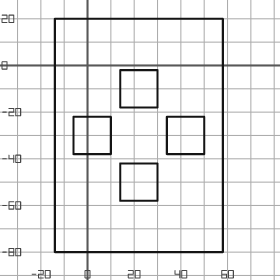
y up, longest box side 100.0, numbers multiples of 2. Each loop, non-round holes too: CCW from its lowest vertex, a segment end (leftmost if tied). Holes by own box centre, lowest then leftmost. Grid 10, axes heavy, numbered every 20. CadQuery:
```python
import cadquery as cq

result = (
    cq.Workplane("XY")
    .moveTo(-14.0, -80.0)
    .lineTo(58.0, -80.0)
    .lineTo(58.0, 20.0)
    .lineTo(-14.0, 20.0)
    .close()
    .moveTo(14.0, -58.0)
    .lineTo(30.0, -58.0)
    .lineTo(30.0, -42.0)
    .lineTo(14.0, -42.0)
    .close()
    .moveTo(-6.0, -38.0)
    .lineTo(10.0, -38.0)
    .lineTo(10.0, -22.0)
    .lineTo(-6.0, -22.0)
    .close()
    .moveTo(34.0, -38.0)
    .lineTo(50.0, -38.0)
    .lineTo(50.0, -22.0)
    .lineTo(34.0, -22.0)
    .close()
    .moveTo(14.0, -18.0)
    .lineTo(30.0, -18.0)
    .lineTo(30.0, -2.0)
    .lineTo(14.0, -2.0)
    .close()
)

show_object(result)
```